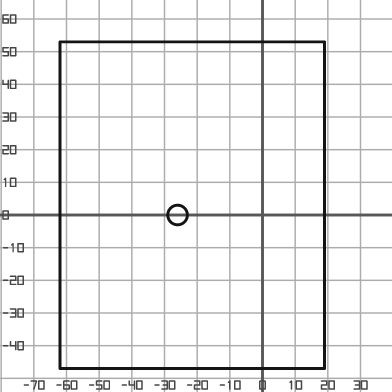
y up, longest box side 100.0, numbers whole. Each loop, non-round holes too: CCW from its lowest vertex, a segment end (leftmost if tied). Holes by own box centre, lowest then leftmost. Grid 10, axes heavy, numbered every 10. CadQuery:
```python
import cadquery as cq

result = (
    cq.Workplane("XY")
    .moveTo(-62.0, -47.0)
    .lineTo(19.0, -47.0)
    .lineTo(19.0, 53.0)
    .lineTo(-62.0, 53.0)
    .close()
    .moveTo(-26.0, 0.0)
    .circle(3.0)
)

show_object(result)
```